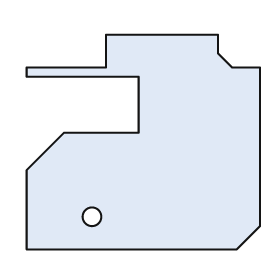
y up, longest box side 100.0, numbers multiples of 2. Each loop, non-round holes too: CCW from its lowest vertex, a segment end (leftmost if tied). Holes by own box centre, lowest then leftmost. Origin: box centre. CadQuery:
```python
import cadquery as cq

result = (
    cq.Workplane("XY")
    .moveTo(-50.0, -46.0)
    .lineTo(40.0, -46.0)
    .lineTo(50.0, -36.0)
    .lineTo(50.0, 32.0)
    .lineTo(38.0, 32.0)
    .lineTo(32.0, 38.0)
    .lineTo(32.0, 46.0)
    .lineTo(-16.0, 46.0)
    .lineTo(-16.0, 32.0)
    .lineTo(-50.0, 32.0)
    .lineTo(-50.0, 28.0)
    .lineTo(-2.0, 28.0)
    .lineTo(-2.0, 4.0)
    .lineTo(-34.0, 4.0)
    .lineTo(-50.0, -12.0)
    .close()
    .moveTo(-22.0, -32.0)
    .circle(4.0)
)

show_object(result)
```